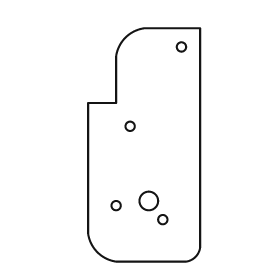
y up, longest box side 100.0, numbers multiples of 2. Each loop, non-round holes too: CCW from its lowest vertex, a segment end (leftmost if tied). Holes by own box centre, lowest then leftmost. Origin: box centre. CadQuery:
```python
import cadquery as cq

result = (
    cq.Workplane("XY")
    .moveTo(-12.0, -50.0)
    .lineTo(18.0, -50.0)
    .threePointArc((22.0, -48.0), (24.0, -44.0))
    .lineTo(24.0, 50.0)
    .lineTo(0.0, 50.0)
    .threePointArc((-8.0, 46.0), (-12.0, 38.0))
    .lineTo(-12.0, 18.0)
    .lineTo(-24.0, 18.0)
    .lineTo(-24.0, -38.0)
    .threePointArc((-20.0, -46.0), (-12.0, -50.0))
    .close()
    .moveTo(8.0, -32.0)
    .circle(2.0)
    .moveTo(-12.0, -26.0)
    .circle(2.0)
    .moveTo(2.0, -24.0)
    .circle(4.0)
    .moveTo(-6.0, 8.0)
    .circle(2.0)
    .moveTo(16.0, 42.0)
    .circle(2.0)
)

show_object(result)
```